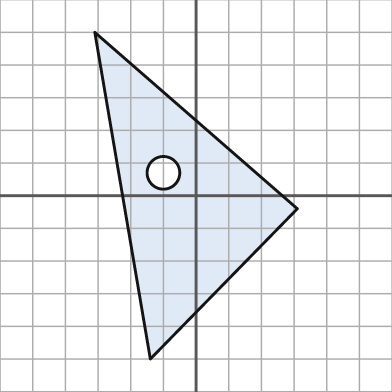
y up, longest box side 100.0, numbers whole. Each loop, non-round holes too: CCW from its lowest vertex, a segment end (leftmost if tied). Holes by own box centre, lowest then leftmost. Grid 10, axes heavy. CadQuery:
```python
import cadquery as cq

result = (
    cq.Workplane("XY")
    .moveTo(-14.0, -50.0)
    .lineTo(31.0, -4.0)
    .lineTo(-31.0, 50.0)
    .close()
    .moveTo(-10.0, 7.0)
    .circle(5.0)
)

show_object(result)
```